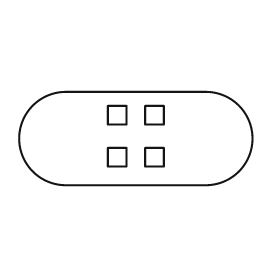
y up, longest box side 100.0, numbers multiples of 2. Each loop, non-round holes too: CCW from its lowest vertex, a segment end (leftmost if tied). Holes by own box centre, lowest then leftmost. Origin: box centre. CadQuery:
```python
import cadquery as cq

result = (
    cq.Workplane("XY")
    .moveTo(-30.0, -20.0)
    .lineTo(30.0, -20.0)
    .threePointArc((50.0, 0.0), (30.0, 20.0))
    .lineTo(-30.0, 20.0)
    .threePointArc((-50.0, 0.0), (-30.0, -20.0))
    .close()
    .moveTo(-12.0, -12.0)
    .lineTo(-4.0, -12.0)
    .lineTo(-4.0, -4.0)
    .lineTo(-12.0, -4.0)
    .close()
    .moveTo(4.0, -12.0)
    .lineTo(12.0, -12.0)
    .lineTo(12.0, -4.0)
    .lineTo(4.0, -4.0)
    .close()
    .moveTo(-12.0, 6.0)
    .lineTo(-4.0, 6.0)
    .lineTo(-4.0, 14.0)
    .lineTo(-12.0, 14.0)
    .close()
    .moveTo(4.0, 6.0)
    .lineTo(12.0, 6.0)
    .lineTo(12.0, 14.0)
    .lineTo(4.0, 14.0)
    .close()
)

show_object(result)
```